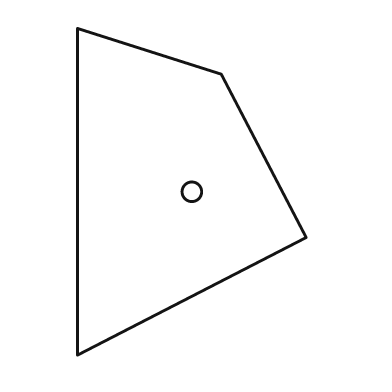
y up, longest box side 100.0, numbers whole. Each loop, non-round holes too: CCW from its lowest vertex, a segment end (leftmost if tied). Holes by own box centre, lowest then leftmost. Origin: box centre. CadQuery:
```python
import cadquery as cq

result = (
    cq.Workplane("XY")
    .moveTo(-35.0, -50.0)
    .lineTo(35.0, -14.0)
    .lineTo(9.0, 36.0)
    .lineTo(-35.0, 50.0)
    .close()
    .moveTo(0.0, 0.0)
    .circle(3.0)
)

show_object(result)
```